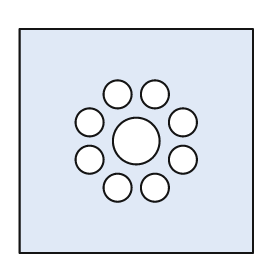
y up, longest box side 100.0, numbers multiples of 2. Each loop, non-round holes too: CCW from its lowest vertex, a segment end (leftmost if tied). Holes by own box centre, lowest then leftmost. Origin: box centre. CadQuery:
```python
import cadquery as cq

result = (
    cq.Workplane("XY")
    .moveTo(-50.0, -48.0)
    .lineTo(50.0, -48.0)
    .lineTo(50.0, 48.0)
    .lineTo(-50.0, 48.0)
    .close()
    .moveTo(-8.0, -20.0)
    .circle(6.0)
    .moveTo(8.0, -20.0)
    .circle(6.0)
    .moveTo(-20.0, -8.0)
    .circle(6.0)
    .moveTo(20.0, -8.0)
    .circle(6.0)
    .moveTo(0.0, 0.0)
    .circle(10.0)
    .moveTo(-20.0, 8.0)
    .circle(6.0)
    .moveTo(20.0, 8.0)
    .circle(6.0)
    .moveTo(-8.0, 20.0)
    .circle(6.0)
    .moveTo(8.0, 20.0)
    .circle(6.0)
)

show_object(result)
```